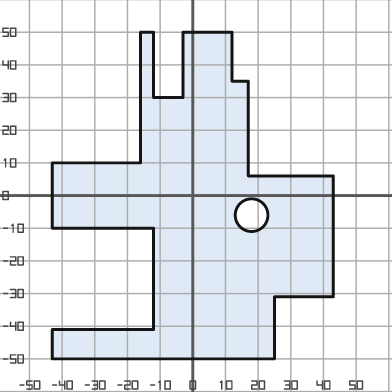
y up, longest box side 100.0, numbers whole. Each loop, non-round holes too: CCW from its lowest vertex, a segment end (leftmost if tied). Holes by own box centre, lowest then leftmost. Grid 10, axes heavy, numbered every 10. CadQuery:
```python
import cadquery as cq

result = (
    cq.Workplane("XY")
    .moveTo(-43.0, -50.0)
    .lineTo(25.0, -50.0)
    .lineTo(25.0, -31.0)
    .lineTo(43.0, -31.0)
    .lineTo(43.0, 6.0)
    .lineTo(17.0, 6.0)
    .lineTo(17.0, 35.0)
    .lineTo(12.0, 35.0)
    .lineTo(12.0, 50.0)
    .lineTo(-3.0, 50.0)
    .lineTo(-3.0, 30.0)
    .lineTo(-12.0, 30.0)
    .lineTo(-12.0, 50.0)
    .lineTo(-16.0, 50.0)
    .lineTo(-16.0, 10.0)
    .lineTo(-43.0, 10.0)
    .lineTo(-43.0, -10.0)
    .lineTo(-12.0, -10.0)
    .lineTo(-12.0, -41.0)
    .lineTo(-43.0, -41.0)
    .close()
    .moveTo(18.0, -6.0)
    .circle(5.0)
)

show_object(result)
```